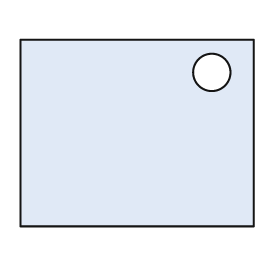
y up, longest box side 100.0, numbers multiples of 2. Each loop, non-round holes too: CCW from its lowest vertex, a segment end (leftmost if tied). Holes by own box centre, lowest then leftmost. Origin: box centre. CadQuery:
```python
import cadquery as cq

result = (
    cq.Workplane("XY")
    .moveTo(-50.0, -40.0)
    .lineTo(50.0, -40.0)
    .lineTo(50.0, 40.0)
    .lineTo(-50.0, 40.0)
    .close()
    .moveTo(32.0, 26.0)
    .circle(8.0)
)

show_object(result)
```